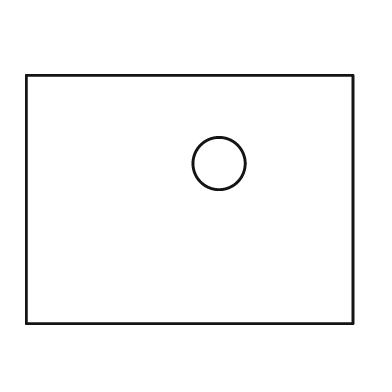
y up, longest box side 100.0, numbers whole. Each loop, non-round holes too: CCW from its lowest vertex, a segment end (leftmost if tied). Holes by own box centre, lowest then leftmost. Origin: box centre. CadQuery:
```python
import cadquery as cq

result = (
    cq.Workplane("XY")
    .moveTo(-50.0, -38.0)
    .lineTo(50.0, -38.0)
    .lineTo(50.0, 38.0)
    .lineTo(-50.0, 38.0)
    .close()
    .moveTo(9.0, 11.0)
    .circle(8.0)
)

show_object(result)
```